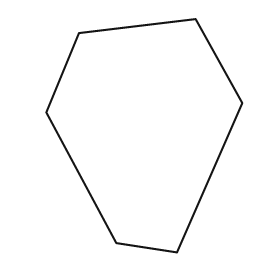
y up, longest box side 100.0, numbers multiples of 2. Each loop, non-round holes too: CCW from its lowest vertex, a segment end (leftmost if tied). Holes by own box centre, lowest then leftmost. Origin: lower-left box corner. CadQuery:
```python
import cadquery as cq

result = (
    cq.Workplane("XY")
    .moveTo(56.0, 0.0)
    .lineTo(84.0, 64.0)
    .lineTo(64.0, 100.0)
    .lineTo(14.0, 94.0)
    .lineTo(0.0, 60.0)
    .lineTo(30.0, 4.0)
    .close()
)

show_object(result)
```